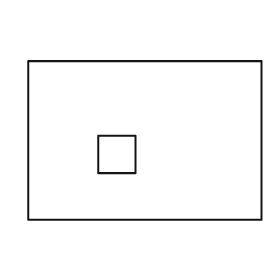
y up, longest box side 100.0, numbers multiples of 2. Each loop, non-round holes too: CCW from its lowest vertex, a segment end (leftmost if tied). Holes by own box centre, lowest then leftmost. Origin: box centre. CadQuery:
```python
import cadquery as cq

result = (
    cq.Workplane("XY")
    .moveTo(-50.0, -34.0)
    .lineTo(50.0, -34.0)
    .lineTo(50.0, 34.0)
    .lineTo(-50.0, 34.0)
    .close()
    .moveTo(-20.0, -14.0)
    .lineTo(-4.0, -14.0)
    .lineTo(-4.0, 2.0)
    .lineTo(-20.0, 2.0)
    .close()
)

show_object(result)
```